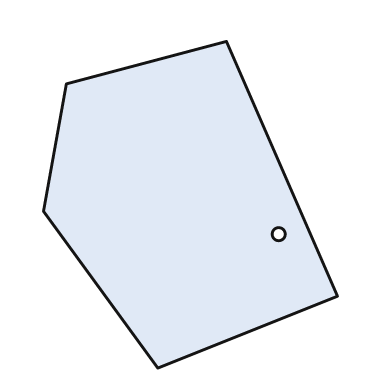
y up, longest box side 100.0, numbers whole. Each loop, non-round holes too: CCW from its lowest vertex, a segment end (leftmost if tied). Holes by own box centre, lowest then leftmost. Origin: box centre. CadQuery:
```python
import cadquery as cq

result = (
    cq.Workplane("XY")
    .moveTo(-10.0, -50.0)
    .lineTo(45.0, -28.0)
    .lineTo(11.0, 50.0)
    .lineTo(-38.0, 37.0)
    .lineTo(-45.0, -2.0)
    .close()
    .moveTo(27.0, -9.0)
    .circle(2.0)
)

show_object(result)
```